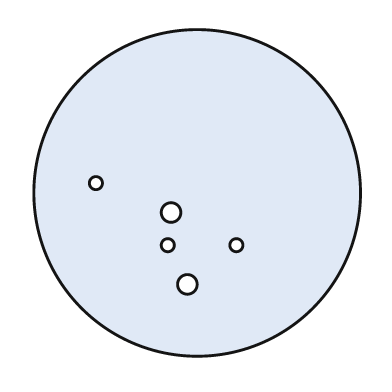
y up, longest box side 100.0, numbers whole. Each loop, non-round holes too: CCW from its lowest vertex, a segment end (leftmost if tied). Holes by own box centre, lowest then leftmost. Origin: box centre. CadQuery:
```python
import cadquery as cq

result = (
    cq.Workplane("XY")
    .moveTo(0.0, 0.0)
    .circle(50.0)
    .moveTo(-3.0, -28.0)
    .circle(3.0)
    .moveTo(-9.0, -16.0)
    .circle(2.0)
    .moveTo(12.0, -16.0)
    .circle(2.0)
    .moveTo(-8.0, -6.0)
    .circle(3.0)
    .moveTo(-31.0, 3.0)
    .circle(2.0)
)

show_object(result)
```